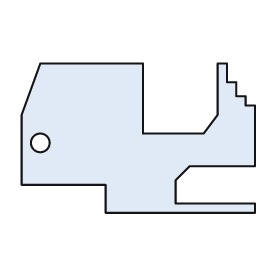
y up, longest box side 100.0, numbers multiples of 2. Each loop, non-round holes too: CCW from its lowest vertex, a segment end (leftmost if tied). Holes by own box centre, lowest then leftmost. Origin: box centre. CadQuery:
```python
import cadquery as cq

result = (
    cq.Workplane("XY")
    .moveTo(-14.0, -32.0)
    .lineTo(50.0, -32.0)
    .lineTo(50.0, -28.0)
    .lineTo(16.0, -28.0)
    .lineTo(16.0, -18.0)
    .lineTo(22.0, -12.0)
    .lineTo(50.0, -12.0)
    .lineTo(50.0, 14.0)
    .lineTo(46.0, 14.0)
    .lineTo(46.0, 18.0)
    .lineTo(42.0, 18.0)
    .lineTo(42.0, 24.0)
    .lineTo(38.0, 24.0)
    .lineTo(38.0, 32.0)
    .lineTo(34.0, 32.0)
    .lineTo(34.0, 10.0)
    .lineTo(28.0, 2.0)
    .lineTo(2.0, 2.0)
    .lineTo(2.0, 32.0)
    .lineTo(-42.0, 32.0)
    .lineTo(-50.0, 10.0)
    .lineTo(-50.0, -20.0)
    .lineTo(-14.0, -20.0)
    .close()
    .moveTo(-42.0, -2.0)
    .circle(4.0)
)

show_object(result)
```